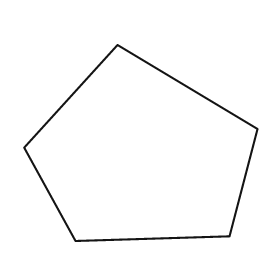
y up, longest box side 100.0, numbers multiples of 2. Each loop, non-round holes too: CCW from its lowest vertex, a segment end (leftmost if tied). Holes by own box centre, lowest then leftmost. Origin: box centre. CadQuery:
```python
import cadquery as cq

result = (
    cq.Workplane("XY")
    .moveTo(-28.0, -42.0)
    .lineTo(38.0, -40.0)
    .lineTo(50.0, 6.0)
    .lineTo(-10.0, 42.0)
    .lineTo(-50.0, -2.0)
    .close()
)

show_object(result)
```